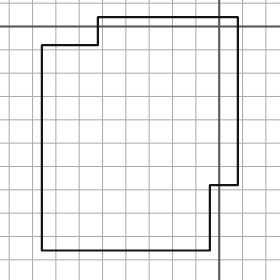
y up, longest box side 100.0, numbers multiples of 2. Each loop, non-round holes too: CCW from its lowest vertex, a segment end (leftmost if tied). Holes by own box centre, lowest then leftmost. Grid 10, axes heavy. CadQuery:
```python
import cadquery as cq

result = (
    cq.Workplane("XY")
    .moveTo(-76.0, -96.0)
    .lineTo(-4.0, -96.0)
    .lineTo(-4.0, -68.0)
    .lineTo(8.0, -68.0)
    .lineTo(8.0, 4.0)
    .lineTo(-52.0, 4.0)
    .lineTo(-52.0, -8.0)
    .lineTo(-76.0, -8.0)
    .close()
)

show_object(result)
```